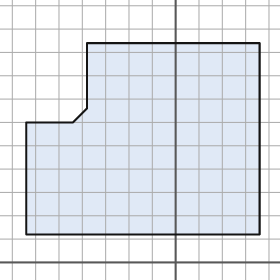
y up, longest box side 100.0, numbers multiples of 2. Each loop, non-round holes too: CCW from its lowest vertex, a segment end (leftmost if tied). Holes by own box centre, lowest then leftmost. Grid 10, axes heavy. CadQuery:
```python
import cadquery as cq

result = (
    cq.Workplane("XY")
    .moveTo(-64.0, 12.0)
    .lineTo(36.0, 12.0)
    .lineTo(36.0, 94.0)
    .lineTo(-38.0, 94.0)
    .lineTo(-38.0, 66.0)
    .lineTo(-44.0, 60.0)
    .lineTo(-64.0, 60.0)
    .close()
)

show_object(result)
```